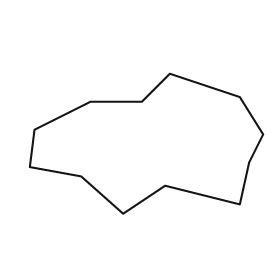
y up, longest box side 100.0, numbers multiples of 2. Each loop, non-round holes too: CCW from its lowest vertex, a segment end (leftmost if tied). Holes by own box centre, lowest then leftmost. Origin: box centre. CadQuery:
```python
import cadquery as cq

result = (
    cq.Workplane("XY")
    .moveTo(-10.0, -30.0)
    .lineTo(8.0, -18.0)
    .lineTo(40.0, -26.0)
    .lineTo(44.0, -8.0)
    .lineTo(50.0, 4.0)
    .lineTo(40.0, 20.0)
    .lineTo(10.0, 30.0)
    .lineTo(-2.0, 18.0)
    .lineTo(-24.0, 18.0)
    .lineTo(-48.0, 6.0)
    .lineTo(-50.0, -10.0)
    .lineTo(-28.0, -14.0)
    .close()
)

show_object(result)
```